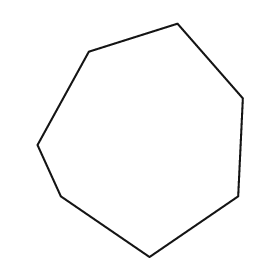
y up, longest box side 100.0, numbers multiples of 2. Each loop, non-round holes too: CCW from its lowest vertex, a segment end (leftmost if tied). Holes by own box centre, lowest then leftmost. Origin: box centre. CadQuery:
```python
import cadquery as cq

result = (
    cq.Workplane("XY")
    .moveTo(4.0, -50.0)
    .lineTo(42.0, -24.0)
    .lineTo(44.0, 18.0)
    .lineTo(16.0, 50.0)
    .lineTo(-22.0, 38.0)
    .lineTo(-44.0, -2.0)
    .lineTo(-34.0, -24.0)
    .close()
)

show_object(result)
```